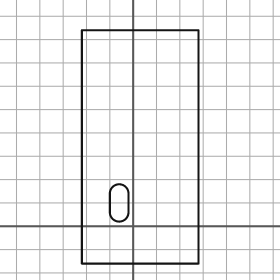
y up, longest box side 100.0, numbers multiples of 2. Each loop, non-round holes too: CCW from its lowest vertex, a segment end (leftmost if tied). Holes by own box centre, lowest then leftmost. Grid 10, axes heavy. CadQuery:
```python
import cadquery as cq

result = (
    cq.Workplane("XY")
    .moveTo(-22.0, -16.0)
    .lineTo(28.0, -16.0)
    .lineTo(28.0, 84.0)
    .lineTo(-22.0, 84.0)
    .close()
    .moveTo(-10.0, 6.0)
    .threePointArc((-6.0, 2.0), (-2.0, 6.0))
    .lineTo(-2.0, 14.0)
    .threePointArc((-6.0, 18.0), (-10.0, 14.0))
    .close()
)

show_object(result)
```